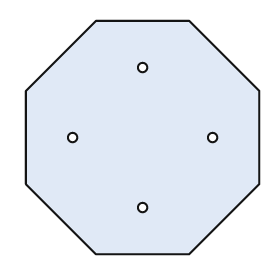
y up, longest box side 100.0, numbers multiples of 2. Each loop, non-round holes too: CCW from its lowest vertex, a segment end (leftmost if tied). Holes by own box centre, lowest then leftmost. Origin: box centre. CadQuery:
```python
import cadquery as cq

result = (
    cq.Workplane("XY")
    .moveTo(-20.0, -50.0)
    .lineTo(20.0, -50.0)
    .lineTo(50.0, -20.0)
    .lineTo(50.0, 20.0)
    .lineTo(20.0, 50.0)
    .lineTo(-20.0, 50.0)
    .lineTo(-50.0, 20.0)
    .lineTo(-50.0, -20.0)
    .close()
    .moveTo(0.0, -30.0)
    .circle(2.0)
    .moveTo(-30.0, 0.0)
    .circle(2.0)
    .moveTo(30.0, 0.0)
    .circle(2.0)
    .moveTo(0.0, 30.0)
    .circle(2.0)
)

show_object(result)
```